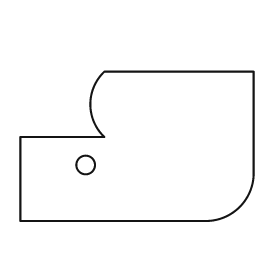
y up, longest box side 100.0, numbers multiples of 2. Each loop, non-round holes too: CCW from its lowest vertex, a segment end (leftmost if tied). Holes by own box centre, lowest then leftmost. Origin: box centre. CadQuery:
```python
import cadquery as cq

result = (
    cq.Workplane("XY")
    .moveTo(-50.0, -32.0)
    .lineTo(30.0, -32.0)
    .threePointArc((44.0, -26.0), (50.0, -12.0))
    .lineTo(50.0, 32.0)
    .lineTo(-14.0, 32.0)
    .threePointArc((-20.0, 18.0), (-14.0, 4.0))
    .lineTo(-50.0, 4.0)
    .close()
    .moveTo(-22.0, -8.0)
    .circle(4.0)
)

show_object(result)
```